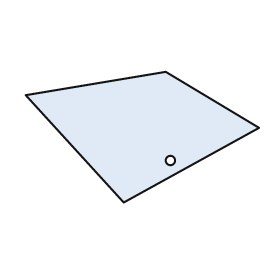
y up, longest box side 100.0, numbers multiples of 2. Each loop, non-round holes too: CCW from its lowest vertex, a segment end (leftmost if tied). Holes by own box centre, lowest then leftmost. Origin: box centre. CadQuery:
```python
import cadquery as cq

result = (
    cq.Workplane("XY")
    .moveTo(-8.0, -28.0)
    .lineTo(50.0, 4.0)
    .lineTo(10.0, 28.0)
    .lineTo(-50.0, 18.0)
    .close()
    .moveTo(12.0, -10.0)
    .circle(2.0)
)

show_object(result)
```